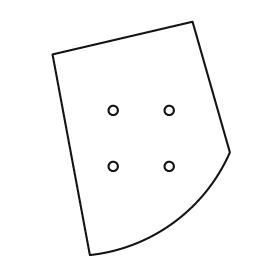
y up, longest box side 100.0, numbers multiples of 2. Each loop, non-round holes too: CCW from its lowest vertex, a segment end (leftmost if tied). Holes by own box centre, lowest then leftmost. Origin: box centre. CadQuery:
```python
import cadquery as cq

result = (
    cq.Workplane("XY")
    .moveTo(-22.0, -50.0)
    .threePointArc((14.0, -36.0), (38.0, -6.0))
    .lineTo(22.0, 50.0)
    .lineTo(-38.0, 36.0)
    .close()
    .moveTo(-12.0, -12.0)
    .circle(2.0)
    .moveTo(12.0, -12.0)
    .circle(2.0)
    .moveTo(-12.0, 12.0)
    .circle(2.0)
    .moveTo(12.0, 12.0)
    .circle(2.0)
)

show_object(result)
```